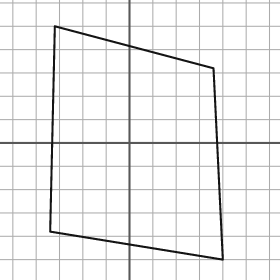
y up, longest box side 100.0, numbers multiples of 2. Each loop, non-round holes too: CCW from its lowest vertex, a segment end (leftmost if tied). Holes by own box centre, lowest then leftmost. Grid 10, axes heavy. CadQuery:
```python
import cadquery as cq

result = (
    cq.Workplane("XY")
    .moveTo(40.0, -50.0)
    .lineTo(36.0, 32.0)
    .lineTo(-32.0, 50.0)
    .lineTo(-34.0, -38.0)
    .close()
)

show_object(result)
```